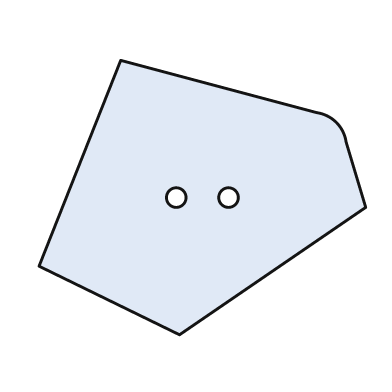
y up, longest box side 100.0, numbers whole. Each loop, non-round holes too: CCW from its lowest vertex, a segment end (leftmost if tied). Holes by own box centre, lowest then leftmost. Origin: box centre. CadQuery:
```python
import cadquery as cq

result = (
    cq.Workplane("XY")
    .moveTo(-7.0, -42.0)
    .lineTo(50.0, -3.0)
    .lineTo(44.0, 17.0)
    .threePointArc((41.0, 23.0), (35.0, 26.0))
    .lineTo(-25.0, 42.0)
    .lineTo(-50.0, -21.0)
    .close()
    .moveTo(-8.0, 0.0)
    .circle(3.0)
    .moveTo(8.0, 0.0)
    .circle(3.0)
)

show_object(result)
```